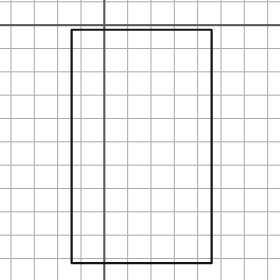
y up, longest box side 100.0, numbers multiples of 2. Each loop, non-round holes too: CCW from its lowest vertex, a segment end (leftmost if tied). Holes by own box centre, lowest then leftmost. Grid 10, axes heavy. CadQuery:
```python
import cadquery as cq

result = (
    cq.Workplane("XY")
    .moveTo(-14.0, -102.0)
    .lineTo(46.0, -102.0)
    .lineTo(46.0, -2.0)
    .lineTo(-14.0, -2.0)
    .close()
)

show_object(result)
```